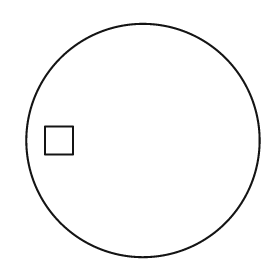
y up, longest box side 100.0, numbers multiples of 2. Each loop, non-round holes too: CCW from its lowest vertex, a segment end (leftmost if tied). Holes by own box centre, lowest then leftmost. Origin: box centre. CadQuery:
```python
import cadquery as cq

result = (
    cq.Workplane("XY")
    .moveTo(0.0, 0.0)
    .circle(50.0)
    .moveTo(-42.0, -6.0)
    .lineTo(-30.0, -6.0)
    .lineTo(-30.0, 6.0)
    .lineTo(-42.0, 6.0)
    .close()
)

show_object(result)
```